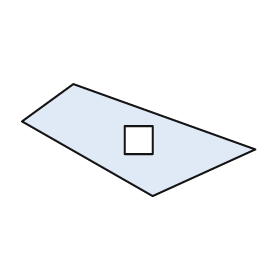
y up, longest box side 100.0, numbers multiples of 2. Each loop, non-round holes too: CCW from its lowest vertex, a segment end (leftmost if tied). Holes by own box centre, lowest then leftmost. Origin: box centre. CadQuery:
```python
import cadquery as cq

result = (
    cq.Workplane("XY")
    .moveTo(6.0, -24.0)
    .lineTo(50.0, -4.0)
    .lineTo(-28.0, 24.0)
    .lineTo(-50.0, 8.0)
    .close()
    .moveTo(-6.0, -6.0)
    .lineTo(6.0, -6.0)
    .lineTo(6.0, 6.0)
    .lineTo(-6.0, 6.0)
    .close()
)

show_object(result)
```